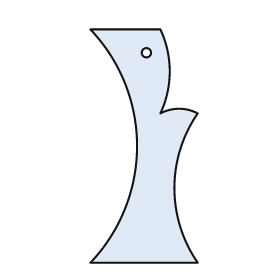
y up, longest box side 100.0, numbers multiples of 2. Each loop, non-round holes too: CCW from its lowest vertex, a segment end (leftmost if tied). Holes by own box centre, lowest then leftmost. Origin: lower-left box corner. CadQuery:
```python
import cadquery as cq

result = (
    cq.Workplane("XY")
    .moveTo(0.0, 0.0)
    .lineTo(46.0, 0.0)
    .threePointArc((36.0, 32.0), (46.0, 64.0))
    .threePointArc((38.0, 66.0), (30.0, 64.0))
    .threePointArc((34.0, 82.0), (30.0, 100.0))
    .lineTo(0.0, 100.0)
    .threePointArc((20.0, 50.0), (0.0, 0.0))
    .close()
    .moveTo(24.0, 90.0)
    .circle(2.0)
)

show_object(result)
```